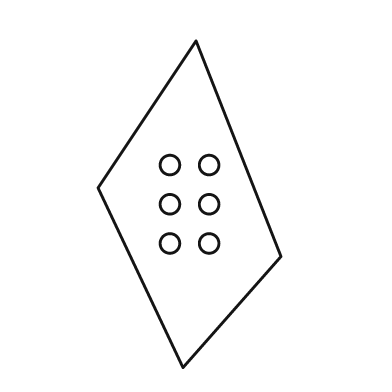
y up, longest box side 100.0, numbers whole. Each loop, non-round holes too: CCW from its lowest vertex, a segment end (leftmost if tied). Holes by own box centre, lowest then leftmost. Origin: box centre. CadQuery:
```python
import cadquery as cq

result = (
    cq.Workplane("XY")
    .moveTo(-2.0, -50.0)
    .lineTo(28.0, -16.0)
    .lineTo(2.0, 50.0)
    .lineTo(-28.0, 5.0)
    .close()
    .moveTo(-6.0, -12.0)
    .circle(3.0)
    .moveTo(6.0, -12.0)
    .circle(3.0)
    .moveTo(-6.0, 0.0)
    .circle(3.0)
    .moveTo(6.0, 0.0)
    .circle(3.0)
    .moveTo(-6.0, 12.0)
    .circle(3.0)
    .moveTo(6.0, 12.0)
    .circle(3.0)
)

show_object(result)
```